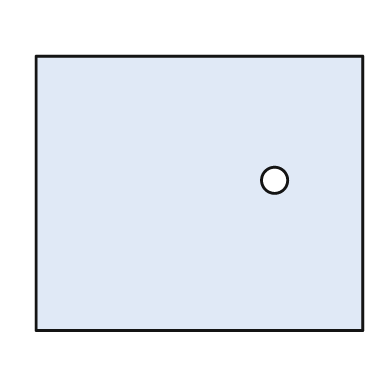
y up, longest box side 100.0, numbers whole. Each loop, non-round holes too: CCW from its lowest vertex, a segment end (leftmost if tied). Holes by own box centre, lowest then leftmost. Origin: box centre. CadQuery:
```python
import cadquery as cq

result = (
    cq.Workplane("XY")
    .moveTo(-50.0, -42.0)
    .lineTo(50.0, -42.0)
    .lineTo(50.0, 42.0)
    .lineTo(-50.0, 42.0)
    .close()
    .moveTo(23.0, 4.0)
    .circle(4.0)
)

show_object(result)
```